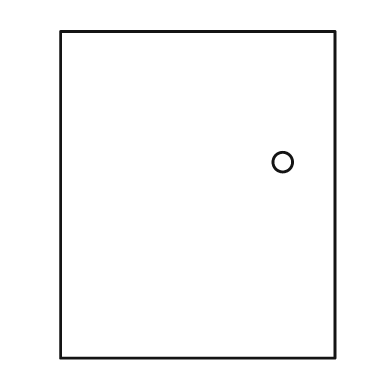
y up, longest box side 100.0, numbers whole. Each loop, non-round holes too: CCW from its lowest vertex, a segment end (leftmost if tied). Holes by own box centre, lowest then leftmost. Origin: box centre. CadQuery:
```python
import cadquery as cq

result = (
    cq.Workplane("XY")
    .moveTo(-42.0, -50.0)
    .lineTo(42.0, -50.0)
    .lineTo(42.0, 50.0)
    .lineTo(-42.0, 50.0)
    .close()
    .moveTo(26.0, 10.0)
    .circle(3.0)
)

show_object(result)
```